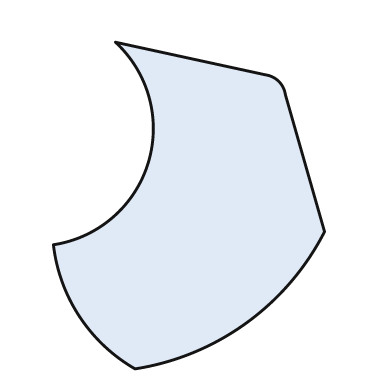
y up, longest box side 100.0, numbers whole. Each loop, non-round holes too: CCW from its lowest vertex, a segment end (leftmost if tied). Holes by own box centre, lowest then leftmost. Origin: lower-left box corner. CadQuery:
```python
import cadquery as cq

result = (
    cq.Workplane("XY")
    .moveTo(25.0, 0.0)
    .threePointArc((59.0, 14.0), (83.0, 42.0))
    .lineTo(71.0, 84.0)
    .threePointArc((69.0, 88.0), (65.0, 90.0))
    .lineTo(19.0, 100.0)
    .threePointArc((29.0, 63.0), (0.0, 38.0))
    .threePointArc((8.0, 16.0), (25.0, 0.0))
    .close()
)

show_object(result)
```